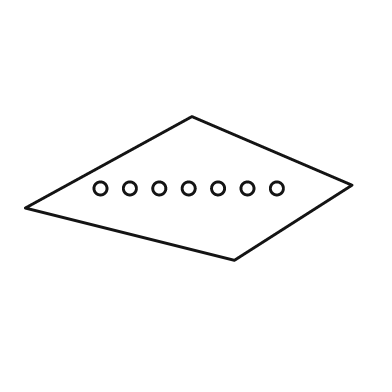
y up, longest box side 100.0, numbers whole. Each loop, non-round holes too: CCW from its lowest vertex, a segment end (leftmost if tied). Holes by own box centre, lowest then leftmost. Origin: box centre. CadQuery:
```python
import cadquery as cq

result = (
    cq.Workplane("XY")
    .moveTo(14.0, -22.0)
    .lineTo(50.0, 1.0)
    .lineTo(1.0, 22.0)
    .lineTo(-50.0, -6.0)
    .close()
    .moveTo(-27.0, 0.0)
    .circle(2.0)
    .moveTo(-18.0, 0.0)
    .circle(2.0)
    .moveTo(-9.0, 0.0)
    .circle(2.0)
    .moveTo(0.0, 0.0)
    .circle(2.0)
    .moveTo(9.0, 0.0)
    .circle(2.0)
    .moveTo(18.0, 0.0)
    .circle(2.0)
    .moveTo(27.0, 0.0)
    .circle(2.0)
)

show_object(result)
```